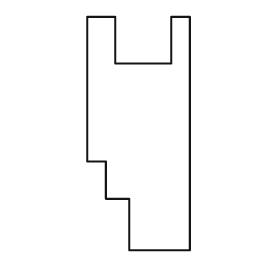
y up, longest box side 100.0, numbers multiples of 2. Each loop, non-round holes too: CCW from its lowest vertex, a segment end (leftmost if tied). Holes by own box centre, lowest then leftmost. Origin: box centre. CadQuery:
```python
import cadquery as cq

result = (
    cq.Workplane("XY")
    .moveTo(-4.0, -50.0)
    .lineTo(22.0, -50.0)
    .lineTo(22.0, 50.0)
    .lineTo(14.0, 50.0)
    .lineTo(14.0, 30.0)
    .lineTo(-10.0, 30.0)
    .lineTo(-10.0, 50.0)
    .lineTo(-22.0, 50.0)
    .lineTo(-22.0, -12.0)
    .lineTo(-14.0, -12.0)
    .lineTo(-14.0, -28.0)
    .lineTo(-4.0, -28.0)
    .close()
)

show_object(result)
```